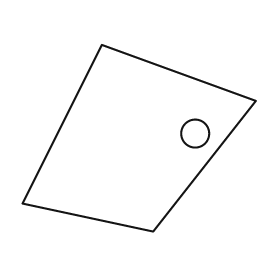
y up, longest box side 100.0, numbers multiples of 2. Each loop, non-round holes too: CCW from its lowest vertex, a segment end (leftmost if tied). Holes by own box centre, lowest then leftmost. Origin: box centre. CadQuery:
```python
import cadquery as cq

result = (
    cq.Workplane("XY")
    .moveTo(6.0, -40.0)
    .lineTo(50.0, 16.0)
    .lineTo(-16.0, 40.0)
    .lineTo(-50.0, -28.0)
    .close()
    .moveTo(24.0, 2.0)
    .circle(6.0)
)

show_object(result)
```